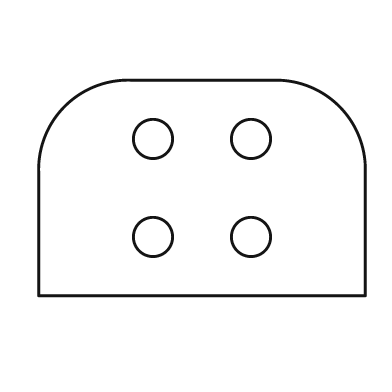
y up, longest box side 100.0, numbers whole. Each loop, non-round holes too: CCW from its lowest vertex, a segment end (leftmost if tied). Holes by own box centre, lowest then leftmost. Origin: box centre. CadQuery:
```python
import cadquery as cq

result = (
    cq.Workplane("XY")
    .moveTo(-50.0, -33.0)
    .lineTo(50.0, -33.0)
    .lineTo(50.0, 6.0)
    .threePointArc((42.0, 25.0), (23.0, 33.0))
    .lineTo(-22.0, 33.0)
    .threePointArc((-42.0, 25.0), (-50.0, 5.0))
    .close()
    .moveTo(-15.0, -15.0)
    .circle(6.0)
    .moveTo(15.0, -15.0)
    .circle(6.0)
    .moveTo(-15.0, 15.0)
    .circle(6.0)
    .moveTo(15.0, 15.0)
    .circle(6.0)
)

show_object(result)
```